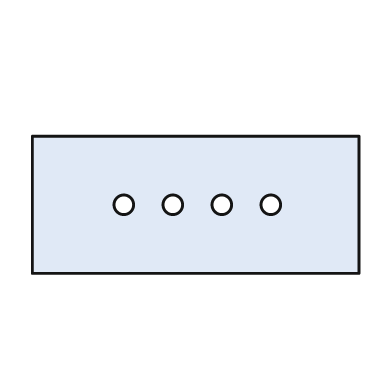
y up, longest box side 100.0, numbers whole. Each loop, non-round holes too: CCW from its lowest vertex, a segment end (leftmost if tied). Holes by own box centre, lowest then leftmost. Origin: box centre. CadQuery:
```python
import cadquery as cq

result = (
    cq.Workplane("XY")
    .moveTo(-50.0, -21.0)
    .lineTo(50.0, -21.0)
    .lineTo(50.0, 21.0)
    .lineTo(-50.0, 21.0)
    .close()
    .moveTo(-22.0, 0.0)
    .circle(3.0)
    .moveTo(-7.0, 0.0)
    .circle(3.0)
    .moveTo(8.0, 0.0)
    .circle(3.0)
    .moveTo(23.0, 0.0)
    .circle(3.0)
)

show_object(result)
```